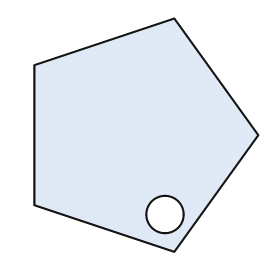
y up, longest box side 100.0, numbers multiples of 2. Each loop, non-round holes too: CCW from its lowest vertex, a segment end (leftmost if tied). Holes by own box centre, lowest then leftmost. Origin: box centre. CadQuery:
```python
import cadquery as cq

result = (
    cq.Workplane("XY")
    .moveTo(12.0, -50.0)
    .lineTo(48.0, 0.0)
    .lineTo(12.0, 50.0)
    .lineTo(-48.0, 30.0)
    .lineTo(-48.0, -30.0)
    .close()
    .moveTo(8.0, -34.0)
    .circle(8.0)
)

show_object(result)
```